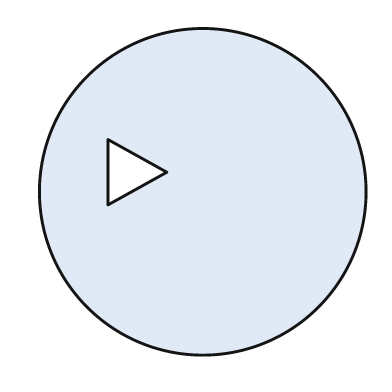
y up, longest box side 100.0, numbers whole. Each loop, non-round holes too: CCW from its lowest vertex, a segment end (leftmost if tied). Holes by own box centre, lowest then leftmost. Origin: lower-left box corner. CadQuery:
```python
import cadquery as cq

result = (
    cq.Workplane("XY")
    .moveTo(50.0, 50.0)
    .circle(50.0)
    .moveTo(21.0, 46.0)
    .lineTo(39.0, 56.0)
    .lineTo(21.0, 66.0)
    .close()
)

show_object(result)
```